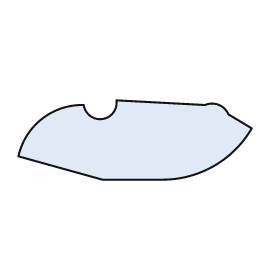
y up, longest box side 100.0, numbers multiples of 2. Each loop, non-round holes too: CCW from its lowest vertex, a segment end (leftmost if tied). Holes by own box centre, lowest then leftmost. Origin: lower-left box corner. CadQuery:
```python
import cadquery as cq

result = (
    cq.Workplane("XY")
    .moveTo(36.0, 0.0)
    .lineTo(62.0, 0.0)
    .threePointArc((84.0, 6.0), (100.0, 22.0))
    .lineTo(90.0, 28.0)
    .threePointArc((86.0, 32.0), (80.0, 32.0))
    .lineTo(42.0, 34.0)
    .threePointArc((36.0, 26.0), (28.0, 32.0))
    .threePointArc((10.0, 26.0), (0.0, 10.0))
    .close()
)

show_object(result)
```